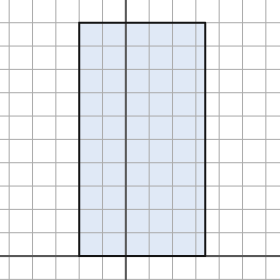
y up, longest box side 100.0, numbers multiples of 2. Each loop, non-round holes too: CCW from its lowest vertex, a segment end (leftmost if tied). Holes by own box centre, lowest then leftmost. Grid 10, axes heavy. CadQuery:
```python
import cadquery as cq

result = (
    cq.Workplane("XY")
    .moveTo(-20.0, 0.0)
    .lineTo(34.0, 0.0)
    .lineTo(34.0, 100.0)
    .lineTo(-20.0, 100.0)
    .close()
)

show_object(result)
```